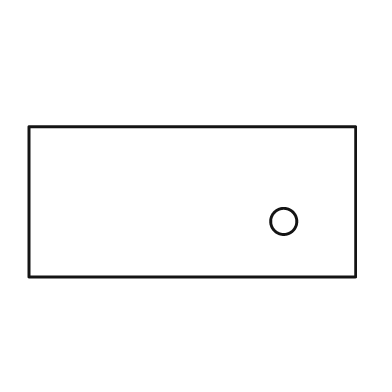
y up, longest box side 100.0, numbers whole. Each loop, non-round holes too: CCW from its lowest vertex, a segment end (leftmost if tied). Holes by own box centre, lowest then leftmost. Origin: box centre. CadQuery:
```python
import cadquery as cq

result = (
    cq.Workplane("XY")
    .moveTo(-50.0, -23.0)
    .lineTo(50.0, -23.0)
    .lineTo(50.0, 23.0)
    .lineTo(-50.0, 23.0)
    .close()
    .moveTo(28.0, -6.0)
    .circle(4.0)
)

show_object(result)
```